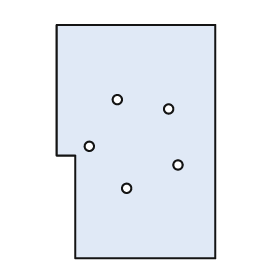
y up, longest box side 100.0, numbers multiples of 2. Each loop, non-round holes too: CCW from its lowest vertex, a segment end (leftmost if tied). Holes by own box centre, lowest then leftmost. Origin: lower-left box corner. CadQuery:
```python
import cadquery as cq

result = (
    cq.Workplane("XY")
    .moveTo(8.0, 0.0)
    .lineTo(68.0, 0.0)
    .lineTo(68.0, 100.0)
    .lineTo(0.0, 100.0)
    .lineTo(0.0, 44.0)
    .lineTo(8.0, 44.0)
    .close()
    .moveTo(30.0, 30.0)
    .circle(2.0)
    .moveTo(52.0, 40.0)
    .circle(2.0)
    .moveTo(14.0, 48.0)
    .circle(2.0)
    .moveTo(48.0, 64.0)
    .circle(2.0)
    .moveTo(26.0, 68.0)
    .circle(2.0)
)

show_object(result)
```